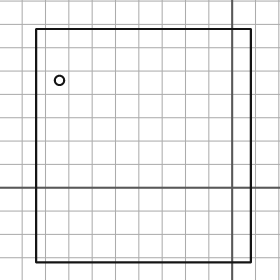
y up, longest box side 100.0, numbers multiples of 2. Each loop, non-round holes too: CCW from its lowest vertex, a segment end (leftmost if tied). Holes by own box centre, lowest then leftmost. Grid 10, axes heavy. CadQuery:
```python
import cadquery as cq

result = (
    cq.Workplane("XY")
    .moveTo(-84.0, -32.0)
    .lineTo(8.0, -32.0)
    .lineTo(8.0, 68.0)
    .lineTo(-84.0, 68.0)
    .close()
    .moveTo(-74.0, 46.0)
    .circle(2.0)
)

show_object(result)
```